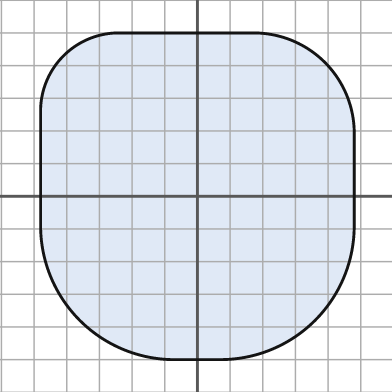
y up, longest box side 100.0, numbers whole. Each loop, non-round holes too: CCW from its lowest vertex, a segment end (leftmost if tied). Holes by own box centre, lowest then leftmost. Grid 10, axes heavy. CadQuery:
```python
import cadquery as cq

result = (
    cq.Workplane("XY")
    .moveTo(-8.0, -50.0)
    .lineTo(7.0, -50.0)
    .threePointArc((36.0, -38.0), (48.0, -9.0))
    .lineTo(48.0, 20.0)
    .threePointArc((39.0, 41.0), (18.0, 50.0))
    .lineTo(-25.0, 50.0)
    .threePointArc((-41.0, 43.0), (-48.0, 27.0))
    .lineTo(-48.0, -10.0)
    .threePointArc((-36.0, -38.0), (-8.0, -50.0))
    .close()
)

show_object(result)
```